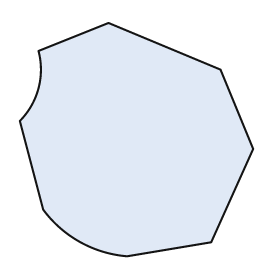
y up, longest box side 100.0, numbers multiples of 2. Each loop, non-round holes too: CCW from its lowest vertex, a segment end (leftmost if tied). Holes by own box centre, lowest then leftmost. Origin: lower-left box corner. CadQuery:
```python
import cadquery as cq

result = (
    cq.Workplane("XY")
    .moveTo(46.0, 0.0)
    .lineTo(82.0, 6.0)
    .lineTo(100.0, 46.0)
    .lineTo(86.0, 80.0)
    .lineTo(38.0, 100.0)
    .lineTo(8.0, 88.0)
    .threePointArc((8.0, 72.0), (0.0, 58.0))
    .lineTo(10.0, 20.0)
    .threePointArc((26.0, 6.0), (46.0, 0.0))
    .close()
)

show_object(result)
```